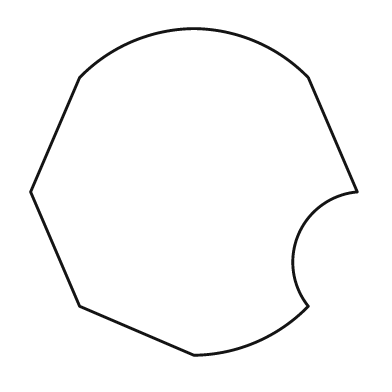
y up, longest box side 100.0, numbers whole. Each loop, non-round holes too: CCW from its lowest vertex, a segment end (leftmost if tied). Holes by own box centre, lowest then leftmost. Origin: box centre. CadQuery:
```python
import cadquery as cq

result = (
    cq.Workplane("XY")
    .moveTo(0.0, -50.0)
    .threePointArc((19.0, -46.0), (35.0, -35.0))
    .threePointArc((32.0, -13.0), (50.0, 0.0))
    .lineTo(35.0, 35.0)
    .threePointArc((19.0, 46.0), (0.0, 50.0))
    .threePointArc((-19.0, 46.0), (-35.0, 35.0))
    .lineTo(-50.0, 0.0)
    .lineTo(-35.0, -35.0)
    .close()
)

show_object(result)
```